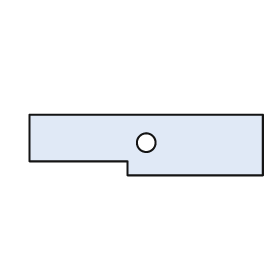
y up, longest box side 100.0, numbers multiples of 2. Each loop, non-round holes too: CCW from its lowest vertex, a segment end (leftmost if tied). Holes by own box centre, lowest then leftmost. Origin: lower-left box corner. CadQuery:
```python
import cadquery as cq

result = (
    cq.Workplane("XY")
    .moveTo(42.0, 0.0)
    .lineTo(100.0, 0.0)
    .lineTo(100.0, 26.0)
    .lineTo(0.0, 26.0)
    .lineTo(0.0, 6.0)
    .lineTo(42.0, 6.0)
    .close()
    .moveTo(50.0, 14.0)
    .circle(4.0)
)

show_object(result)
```